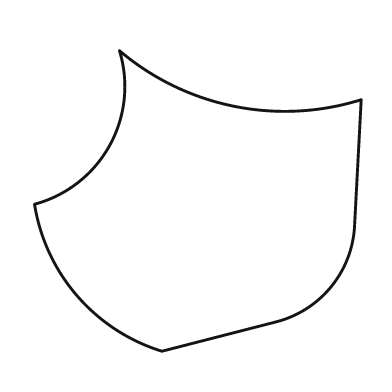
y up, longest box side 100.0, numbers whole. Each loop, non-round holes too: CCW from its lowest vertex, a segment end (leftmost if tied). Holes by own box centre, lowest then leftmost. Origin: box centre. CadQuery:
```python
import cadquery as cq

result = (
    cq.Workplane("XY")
    .moveTo(-11.0, -46.0)
    .lineTo(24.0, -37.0)
    .threePointArc((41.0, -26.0), (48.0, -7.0))
    .lineTo(50.0, 31.0)
    .threePointArc((11.0, 29.0), (-24.0, 46.0))
    .threePointArc((-27.0, 17.0), (-50.0, -1.0))
    .threePointArc((-37.0, -29.0), (-11.0, -46.0))
    .close()
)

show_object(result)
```